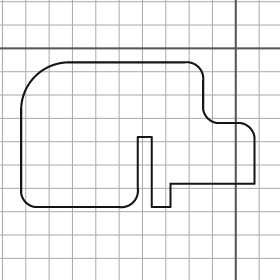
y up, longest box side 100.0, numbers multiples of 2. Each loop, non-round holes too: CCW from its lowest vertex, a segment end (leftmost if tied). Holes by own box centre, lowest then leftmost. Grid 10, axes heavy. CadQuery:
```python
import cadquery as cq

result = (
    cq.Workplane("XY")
    .moveTo(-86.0, -68.0)
    .lineTo(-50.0, -68.0)
    .threePointArc((-44.0, -66.0), (-42.0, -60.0))
    .lineTo(-42.0, -38.0)
    .lineTo(-36.0, -38.0)
    .lineTo(-36.0, -68.0)
    .lineTo(-28.0, -68.0)
    .lineTo(-28.0, -58.0)
    .lineTo(8.0, -58.0)
    .lineTo(8.0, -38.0)
    .threePointArc((6.0, -34.0), (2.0, -32.0))
    .lineTo(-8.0, -32.0)
    .threePointArc((-12.0, -30.0), (-14.0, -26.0))
    .lineTo(-14.0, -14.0)
    .threePointArc((-16.0, -8.0), (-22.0, -6.0))
    .lineTo(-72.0, -6.0)
    .threePointArc((-86.0, -12.0), (-92.0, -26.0))
    .lineTo(-92.0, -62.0)
    .threePointArc((-90.0, -66.0), (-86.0, -68.0))
    .close()
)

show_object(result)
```